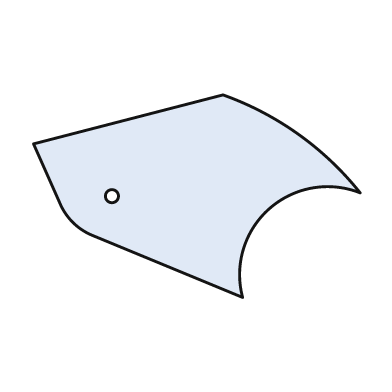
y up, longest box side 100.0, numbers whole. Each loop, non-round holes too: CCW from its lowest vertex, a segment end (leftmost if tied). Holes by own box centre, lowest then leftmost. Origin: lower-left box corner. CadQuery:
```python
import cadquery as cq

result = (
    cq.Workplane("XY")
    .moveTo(64.0, 0.0)
    .threePointArc((72.0, 27.0), (100.0, 32.0))
    .threePointArc((81.0, 50.0), (58.0, 62.0))
    .lineTo(0.0, 47.0)
    .lineTo(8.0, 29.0)
    .threePointArc((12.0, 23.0), (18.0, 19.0))
    .close()
    .moveTo(24.0, 31.0)
    .circle(2.0)
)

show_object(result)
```